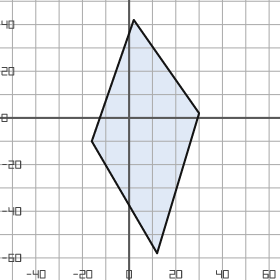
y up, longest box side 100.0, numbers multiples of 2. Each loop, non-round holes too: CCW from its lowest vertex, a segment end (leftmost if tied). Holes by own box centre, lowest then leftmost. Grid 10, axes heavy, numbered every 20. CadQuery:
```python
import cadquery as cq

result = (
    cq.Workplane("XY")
    .moveTo(12.0, -58.0)
    .lineTo(30.0, 2.0)
    .lineTo(2.0, 42.0)
    .lineTo(-16.0, -10.0)
    .close()
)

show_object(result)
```